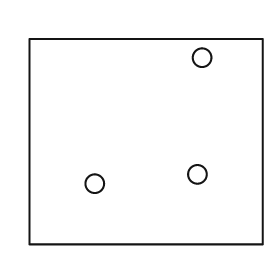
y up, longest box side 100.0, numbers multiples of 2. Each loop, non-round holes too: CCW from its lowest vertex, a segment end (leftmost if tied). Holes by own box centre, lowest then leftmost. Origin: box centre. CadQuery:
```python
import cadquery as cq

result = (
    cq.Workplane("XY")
    .moveTo(-50.0, -44.0)
    .lineTo(50.0, -44.0)
    .lineTo(50.0, 44.0)
    .lineTo(-50.0, 44.0)
    .close()
    .moveTo(-22.0, -18.0)
    .circle(4.0)
    .moveTo(22.0, -14.0)
    .circle(4.0)
    .moveTo(24.0, 36.0)
    .circle(4.0)
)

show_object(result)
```